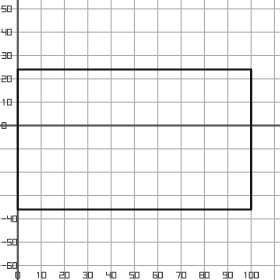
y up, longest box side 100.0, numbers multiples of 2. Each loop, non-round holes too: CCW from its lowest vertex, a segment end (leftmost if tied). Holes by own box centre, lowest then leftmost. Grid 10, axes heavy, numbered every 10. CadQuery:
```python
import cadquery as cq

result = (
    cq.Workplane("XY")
    .moveTo(0.0, -36.0)
    .lineTo(100.0, -36.0)
    .lineTo(100.0, 24.0)
    .lineTo(0.0, 24.0)
    .close()
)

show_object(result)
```